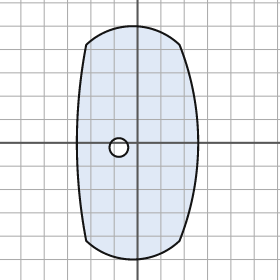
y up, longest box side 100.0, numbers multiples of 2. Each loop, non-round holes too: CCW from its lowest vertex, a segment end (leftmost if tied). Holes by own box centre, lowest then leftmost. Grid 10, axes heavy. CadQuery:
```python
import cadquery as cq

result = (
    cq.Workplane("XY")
    .moveTo(-22.0, -42.0)
    .threePointArc((-2.0, -50.0), (18.0, -42.0))
    .threePointArc((26.0, 0.0), (18.0, 42.0))
    .threePointArc((-2.0, 50.0), (-22.0, 42.0))
    .threePointArc((-26.0, 0.0), (-22.0, -42.0))
    .close()
    .moveTo(-8.0, -2.0)
    .circle(4.0)
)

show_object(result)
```